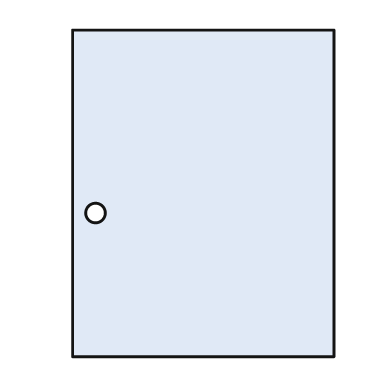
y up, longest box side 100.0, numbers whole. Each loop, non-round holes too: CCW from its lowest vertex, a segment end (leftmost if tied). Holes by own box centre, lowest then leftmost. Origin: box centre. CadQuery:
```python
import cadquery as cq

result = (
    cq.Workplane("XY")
    .moveTo(-40.0, -50.0)
    .lineTo(40.0, -50.0)
    .lineTo(40.0, 50.0)
    .lineTo(-40.0, 50.0)
    .close()
    .moveTo(-33.0, -6.0)
    .circle(3.0)
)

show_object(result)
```